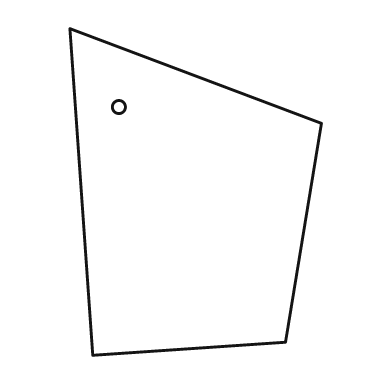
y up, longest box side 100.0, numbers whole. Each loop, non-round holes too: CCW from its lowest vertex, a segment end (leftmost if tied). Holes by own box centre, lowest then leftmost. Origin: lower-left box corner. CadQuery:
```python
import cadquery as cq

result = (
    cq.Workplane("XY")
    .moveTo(7.0, 0.0)
    .lineTo(66.0, 4.0)
    .lineTo(77.0, 71.0)
    .lineTo(0.0, 100.0)
    .close()
    .moveTo(15.0, 76.0)
    .circle(2.0)
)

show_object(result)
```